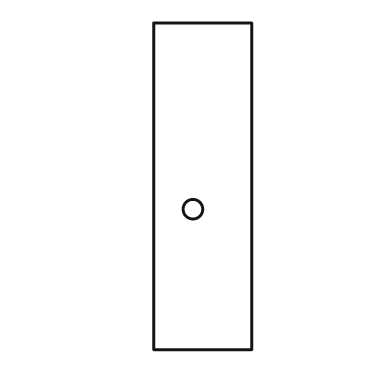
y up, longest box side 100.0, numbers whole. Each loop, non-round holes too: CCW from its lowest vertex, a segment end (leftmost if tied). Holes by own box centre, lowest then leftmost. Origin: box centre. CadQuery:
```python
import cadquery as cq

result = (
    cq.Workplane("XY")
    .moveTo(-15.0, -50.0)
    .lineTo(15.0, -50.0)
    .lineTo(15.0, 50.0)
    .lineTo(-15.0, 50.0)
    .close()
    .moveTo(-3.0, -7.0)
    .circle(3.0)
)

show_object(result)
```